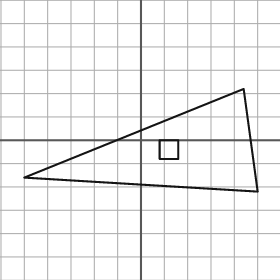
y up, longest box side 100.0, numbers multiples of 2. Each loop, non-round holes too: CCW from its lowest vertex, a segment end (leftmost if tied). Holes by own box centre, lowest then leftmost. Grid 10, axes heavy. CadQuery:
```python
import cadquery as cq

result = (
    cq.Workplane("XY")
    .moveTo(50.0, -22.0)
    .lineTo(44.0, 22.0)
    .lineTo(-50.0, -16.0)
    .close()
    .moveTo(8.0, -8.0)
    .lineTo(16.0, -8.0)
    .lineTo(16.0, 0.0)
    .lineTo(8.0, 0.0)
    .close()
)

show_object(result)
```